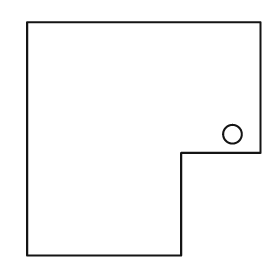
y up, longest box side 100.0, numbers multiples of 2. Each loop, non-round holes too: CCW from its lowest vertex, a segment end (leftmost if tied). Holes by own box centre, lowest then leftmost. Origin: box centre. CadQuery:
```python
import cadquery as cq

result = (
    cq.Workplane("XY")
    .moveTo(-50.0, -50.0)
    .lineTo(16.0, -50.0)
    .lineTo(16.0, -6.0)
    .lineTo(50.0, -6.0)
    .lineTo(50.0, 50.0)
    .lineTo(-50.0, 50.0)
    .close()
    .moveTo(38.0, 2.0)
    .circle(4.0)
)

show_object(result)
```